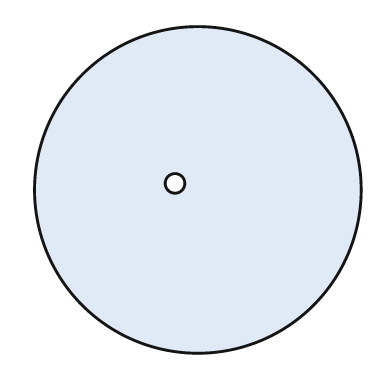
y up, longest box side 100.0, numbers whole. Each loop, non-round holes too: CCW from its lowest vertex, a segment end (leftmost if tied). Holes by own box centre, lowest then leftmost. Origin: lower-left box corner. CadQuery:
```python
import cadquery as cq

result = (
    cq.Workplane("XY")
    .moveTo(50.0, 50.0)
    .circle(50.0)
    .moveTo(43.0, 52.0)
    .circle(3.0)
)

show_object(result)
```